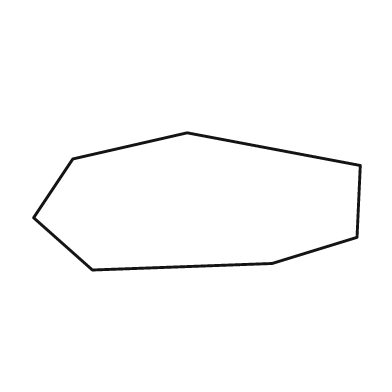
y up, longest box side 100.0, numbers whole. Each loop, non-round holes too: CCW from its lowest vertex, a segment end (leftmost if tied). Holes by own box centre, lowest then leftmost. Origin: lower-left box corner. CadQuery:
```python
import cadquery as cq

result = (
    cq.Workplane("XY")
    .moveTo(18.0, 0.0)
    .lineTo(73.0, 2.0)
    .lineTo(99.0, 10.0)
    .lineTo(100.0, 32.0)
    .lineTo(47.0, 42.0)
    .lineTo(12.0, 34.0)
    .lineTo(0.0, 16.0)
    .close()
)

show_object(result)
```